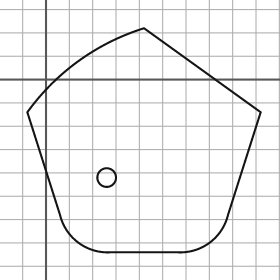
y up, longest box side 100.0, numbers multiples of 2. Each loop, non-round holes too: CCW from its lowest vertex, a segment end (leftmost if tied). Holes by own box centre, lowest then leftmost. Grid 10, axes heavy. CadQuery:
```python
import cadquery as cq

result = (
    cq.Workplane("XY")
    .moveTo(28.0, -74.0)
    .lineTo(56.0, -74.0)
    .threePointArc((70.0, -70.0), (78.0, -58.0))
    .lineTo(92.0, -14.0)
    .lineTo(42.0, 22.0)
    .threePointArc((14.0, 8.0), (-8.0, -14.0))
    .lineTo(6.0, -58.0)
    .threePointArc((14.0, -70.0), (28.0, -74.0))
    .close()
    .moveTo(26.0, -42.0)
    .circle(4.0)
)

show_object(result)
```